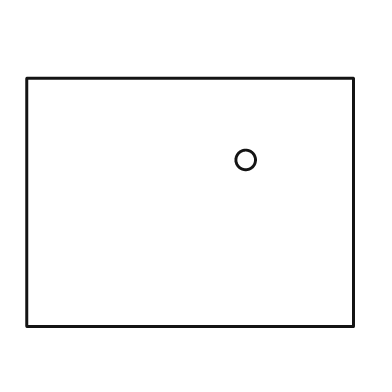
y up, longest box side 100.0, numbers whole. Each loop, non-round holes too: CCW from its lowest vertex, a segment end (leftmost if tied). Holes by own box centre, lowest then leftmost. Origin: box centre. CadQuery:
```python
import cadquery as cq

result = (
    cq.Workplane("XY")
    .moveTo(-50.0, -38.0)
    .lineTo(50.0, -38.0)
    .lineTo(50.0, 38.0)
    .lineTo(-50.0, 38.0)
    .close()
    .moveTo(17.0, 13.0)
    .circle(3.0)
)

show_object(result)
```